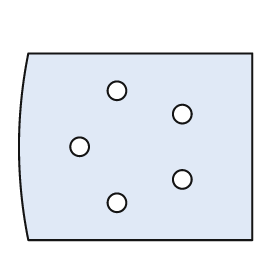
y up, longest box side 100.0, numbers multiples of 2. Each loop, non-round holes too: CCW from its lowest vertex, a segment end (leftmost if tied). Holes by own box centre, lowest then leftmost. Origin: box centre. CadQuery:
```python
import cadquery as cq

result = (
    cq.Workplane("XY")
    .moveTo(-46.0, -40.0)
    .lineTo(50.0, -40.0)
    .lineTo(50.0, 40.0)
    .lineTo(-46.0, 40.0)
    .threePointArc((-50.0, 0.0), (-46.0, -40.0))
    .close()
    .moveTo(-8.0, -24.0)
    .circle(4.0)
    .moveTo(20.0, -14.0)
    .circle(4.0)
    .moveTo(-24.0, 0.0)
    .circle(4.0)
    .moveTo(20.0, 14.0)
    .circle(4.0)
    .moveTo(-8.0, 24.0)
    .circle(4.0)
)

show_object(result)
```